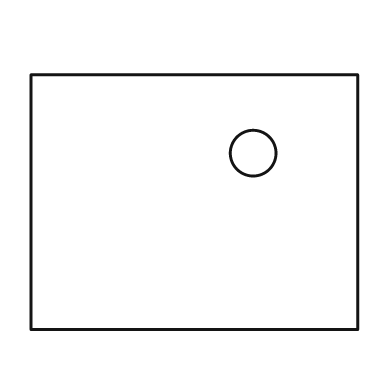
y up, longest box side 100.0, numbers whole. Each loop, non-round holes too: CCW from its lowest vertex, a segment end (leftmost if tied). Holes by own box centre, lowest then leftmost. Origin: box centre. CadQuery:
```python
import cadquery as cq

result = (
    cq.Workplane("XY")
    .moveTo(-50.0, -39.0)
    .lineTo(50.0, -39.0)
    .lineTo(50.0, 39.0)
    .lineTo(-50.0, 39.0)
    .close()
    .moveTo(18.0, 15.0)
    .circle(7.0)
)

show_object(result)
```